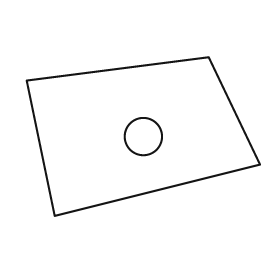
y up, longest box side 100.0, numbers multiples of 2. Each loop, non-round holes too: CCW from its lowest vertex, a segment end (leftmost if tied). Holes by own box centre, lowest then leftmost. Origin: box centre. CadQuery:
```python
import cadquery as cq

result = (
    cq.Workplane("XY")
    .moveTo(-38.0, -34.0)
    .lineTo(50.0, -12.0)
    .lineTo(28.0, 34.0)
    .lineTo(-50.0, 24.0)
    .close()
    .moveTo(0.0, 0.0)
    .circle(8.0)
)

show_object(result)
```